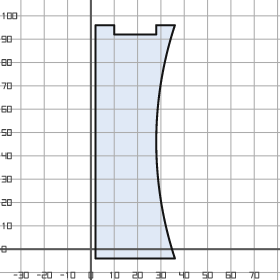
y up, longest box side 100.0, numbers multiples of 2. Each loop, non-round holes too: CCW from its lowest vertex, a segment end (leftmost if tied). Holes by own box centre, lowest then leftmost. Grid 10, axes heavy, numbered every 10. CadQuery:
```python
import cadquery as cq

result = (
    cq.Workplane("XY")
    .moveTo(2.0, -4.0)
    .lineTo(36.0, -4.0)
    .threePointArc((28.0, 46.0), (36.0, 96.0))
    .lineTo(28.0, 96.0)
    .lineTo(28.0, 92.0)
    .lineTo(10.0, 92.0)
    .lineTo(10.0, 96.0)
    .lineTo(2.0, 96.0)
    .close()
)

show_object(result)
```